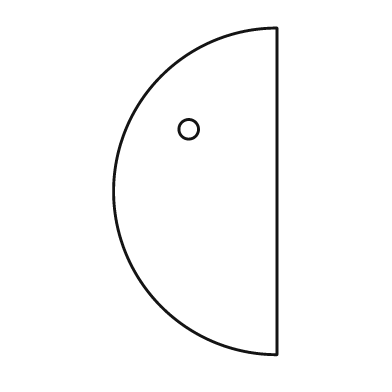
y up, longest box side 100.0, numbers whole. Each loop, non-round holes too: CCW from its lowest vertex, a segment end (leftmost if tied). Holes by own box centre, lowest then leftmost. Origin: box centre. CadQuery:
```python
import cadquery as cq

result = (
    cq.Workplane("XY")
    .moveTo(25.0, -50.0)
    .lineTo(25.0, 50.0)
    .threePointArc((-25.0, 0.0), (25.0, -50.0))
    .close()
    .moveTo(-2.0, 19.0)
    .circle(3.0)
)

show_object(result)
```